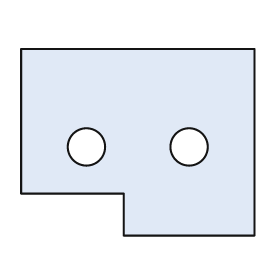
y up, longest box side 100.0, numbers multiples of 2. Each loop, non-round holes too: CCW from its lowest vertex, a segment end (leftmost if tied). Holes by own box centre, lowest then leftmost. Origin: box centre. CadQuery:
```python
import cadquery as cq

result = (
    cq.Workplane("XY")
    .moveTo(-6.0, -40.0)
    .lineTo(50.0, -40.0)
    .lineTo(50.0, 40.0)
    .lineTo(-50.0, 40.0)
    .lineTo(-50.0, -22.0)
    .lineTo(-6.0, -22.0)
    .close()
    .moveTo(-22.0, -2.0)
    .circle(8.0)
    .moveTo(22.0, -2.0)
    .circle(8.0)
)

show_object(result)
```